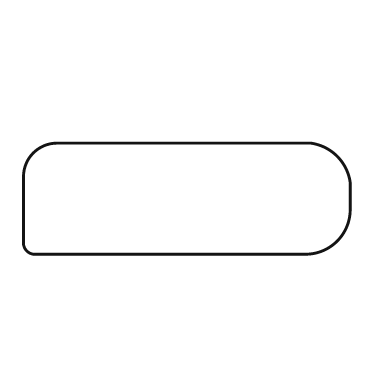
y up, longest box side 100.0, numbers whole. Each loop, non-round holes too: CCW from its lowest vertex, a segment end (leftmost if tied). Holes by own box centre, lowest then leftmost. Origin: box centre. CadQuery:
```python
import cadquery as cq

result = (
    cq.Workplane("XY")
    .moveTo(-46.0, -17.0)
    .lineTo(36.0, -17.0)
    .threePointArc((46.0, -13.0), (50.0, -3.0))
    .lineTo(50.0, 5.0)
    .threePointArc((46.0, 13.0), (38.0, 17.0))
    .lineTo(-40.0, 17.0)
    .threePointArc((-47.0, 14.0), (-50.0, 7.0))
    .lineTo(-50.0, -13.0)
    .threePointArc((-49.0, -16.0), (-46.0, -17.0))
    .close()
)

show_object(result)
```